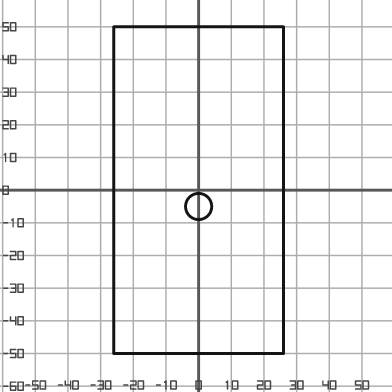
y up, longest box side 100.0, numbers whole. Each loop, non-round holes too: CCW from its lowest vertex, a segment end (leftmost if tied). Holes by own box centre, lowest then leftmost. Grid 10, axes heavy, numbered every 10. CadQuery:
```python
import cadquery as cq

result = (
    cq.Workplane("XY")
    .moveTo(-26.0, -50.0)
    .lineTo(26.0, -50.0)
    .lineTo(26.0, 50.0)
    .lineTo(-26.0, 50.0)
    .close()
    .moveTo(0.0, -5.0)
    .circle(4.0)
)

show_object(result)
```